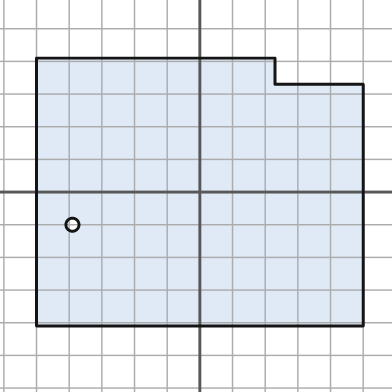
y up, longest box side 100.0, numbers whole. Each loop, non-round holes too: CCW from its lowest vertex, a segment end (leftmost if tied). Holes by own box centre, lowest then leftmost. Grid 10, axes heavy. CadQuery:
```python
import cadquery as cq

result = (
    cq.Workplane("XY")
    .moveTo(-50.0, -41.0)
    .lineTo(50.0, -41.0)
    .lineTo(50.0, 33.0)
    .lineTo(23.0, 33.0)
    .lineTo(23.0, 41.0)
    .lineTo(-50.0, 41.0)
    .close()
    .moveTo(-39.0, -10.0)
    .circle(2.0)
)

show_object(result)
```